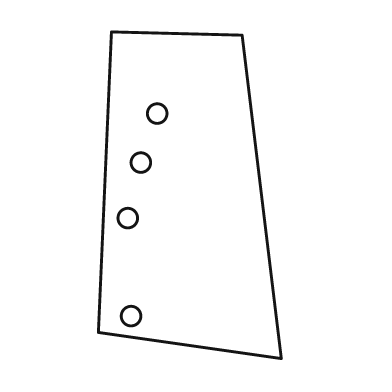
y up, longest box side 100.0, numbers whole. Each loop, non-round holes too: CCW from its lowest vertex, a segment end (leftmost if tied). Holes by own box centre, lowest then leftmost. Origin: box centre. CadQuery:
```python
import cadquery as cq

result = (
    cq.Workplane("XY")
    .moveTo(28.0, -50.0)
    .lineTo(16.0, 49.0)
    .lineTo(-24.0, 50.0)
    .lineTo(-28.0, -42.0)
    .close()
    .moveTo(-18.0, -37.0)
    .circle(3.0)
    .moveTo(-19.0, -7.0)
    .circle(3.0)
    .moveTo(-15.0, 10.0)
    .circle(3.0)
    .moveTo(-10.0, 25.0)
    .circle(3.0)
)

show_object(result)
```